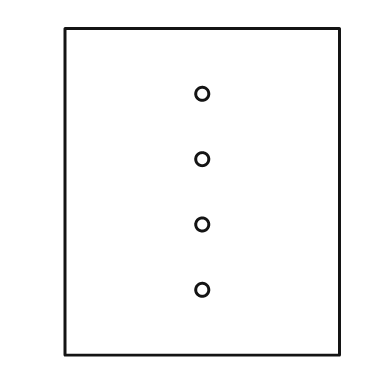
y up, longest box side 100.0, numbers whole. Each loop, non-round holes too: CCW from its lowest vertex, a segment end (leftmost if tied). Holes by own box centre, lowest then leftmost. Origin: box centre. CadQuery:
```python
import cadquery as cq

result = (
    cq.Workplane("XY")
    .moveTo(-42.0, -50.0)
    .lineTo(42.0, -50.0)
    .lineTo(42.0, 50.0)
    .lineTo(-42.0, 50.0)
    .close()
    .moveTo(0.0, -30.0)
    .circle(2.0)
    .moveTo(0.0, -10.0)
    .circle(2.0)
    .moveTo(0.0, 10.0)
    .circle(2.0)
    .moveTo(0.0, 30.0)
    .circle(2.0)
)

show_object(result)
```